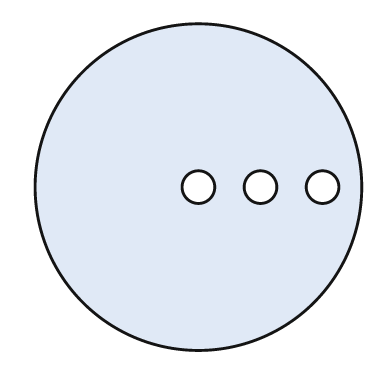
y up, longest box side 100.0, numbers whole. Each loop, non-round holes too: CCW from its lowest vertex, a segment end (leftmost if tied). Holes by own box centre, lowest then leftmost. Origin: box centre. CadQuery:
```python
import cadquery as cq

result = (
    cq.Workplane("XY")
    .moveTo(0.0, 0.0)
    .circle(50.0)
    .moveTo(0.0, 0.0)
    .circle(5.0)
    .moveTo(19.0, 0.0)
    .circle(5.0)
    .moveTo(38.0, 0.0)
    .circle(5.0)
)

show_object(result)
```